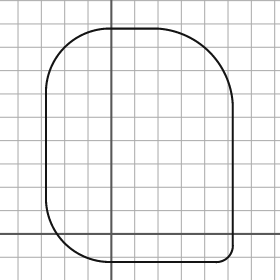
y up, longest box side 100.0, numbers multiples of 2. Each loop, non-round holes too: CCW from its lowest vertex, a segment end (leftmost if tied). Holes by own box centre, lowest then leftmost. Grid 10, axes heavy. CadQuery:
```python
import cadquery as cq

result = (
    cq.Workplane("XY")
    .moveTo(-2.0, -12.0)
    .lineTo(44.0, -12.0)
    .threePointArc((50.0, -10.0), (52.0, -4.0))
    .lineTo(52.0, 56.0)
    .threePointArc((42.0, 78.0), (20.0, 88.0))
    .lineTo(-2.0, 88.0)
    .threePointArc((-20.0, 80.0), (-28.0, 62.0))
    .lineTo(-28.0, 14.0)
    .threePointArc((-20.0, -4.0), (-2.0, -12.0))
    .close()
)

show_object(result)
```